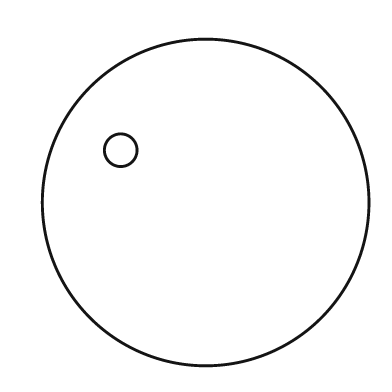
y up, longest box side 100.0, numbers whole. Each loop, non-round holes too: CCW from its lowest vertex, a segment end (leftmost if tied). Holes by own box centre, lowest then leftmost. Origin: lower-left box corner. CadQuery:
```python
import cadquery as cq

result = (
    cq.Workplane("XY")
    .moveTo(50.0, 50.0)
    .circle(50.0)
    .moveTo(24.0, 66.0)
    .circle(5.0)
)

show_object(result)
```